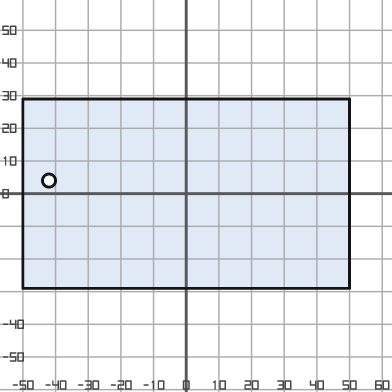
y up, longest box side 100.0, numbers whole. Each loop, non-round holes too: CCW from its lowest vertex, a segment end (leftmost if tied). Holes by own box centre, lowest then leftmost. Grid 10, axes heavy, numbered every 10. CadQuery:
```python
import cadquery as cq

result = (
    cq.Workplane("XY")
    .moveTo(-50.0, -29.0)
    .lineTo(50.0, -29.0)
    .lineTo(50.0, 29.0)
    .lineTo(-50.0, 29.0)
    .close()
    .moveTo(-42.0, 4.0)
    .circle(2.0)
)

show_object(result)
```